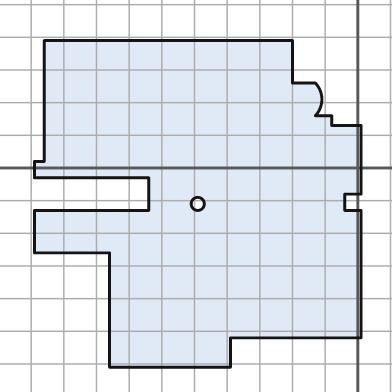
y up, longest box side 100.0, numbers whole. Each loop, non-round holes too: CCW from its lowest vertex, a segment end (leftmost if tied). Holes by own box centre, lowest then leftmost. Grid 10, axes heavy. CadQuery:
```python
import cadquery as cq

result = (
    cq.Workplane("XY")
    .moveTo(-76.0, -61.0)
    .lineTo(-39.0, -61.0)
    .lineTo(-39.0, -52.0)
    .lineTo(1.0, -52.0)
    .lineTo(1.0, -13.0)
    .lineTo(-4.0, -13.0)
    .lineTo(-4.0, -8.0)
    .lineTo(1.0, -8.0)
    .lineTo(1.0, 13.0)
    .lineTo(-8.0, 13.0)
    .lineTo(-8.0, 16.0)
    .lineTo(-13.0, 16.0)
    .threePointArc((-11.0, 21.0), (-13.0, 26.0))
    .lineTo(-20.0, 26.0)
    .lineTo(-20.0, 39.0)
    .lineTo(-96.0, 39.0)
    .lineTo(-96.0, 2.0)
    .lineTo(-99.0, 2.0)
    .lineTo(-99.0, -3.0)
    .lineTo(-64.0, -3.0)
    .lineTo(-64.0, -13.0)
    .lineTo(-99.0, -13.0)
    .lineTo(-99.0, -26.0)
    .lineTo(-76.0, -26.0)
    .close()
    .moveTo(-49.0, -11.0)
    .circle(2.0)
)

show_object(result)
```